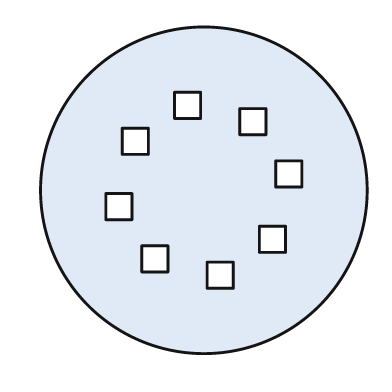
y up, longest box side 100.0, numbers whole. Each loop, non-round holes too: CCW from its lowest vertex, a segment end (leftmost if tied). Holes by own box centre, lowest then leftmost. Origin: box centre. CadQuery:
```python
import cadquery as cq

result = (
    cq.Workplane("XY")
    .moveTo(0.0, 0.0)
    .circle(50.0)
    .moveTo(1.0, -30.0)
    .lineTo(9.0, -30.0)
    .lineTo(9.0, -22.0)
    .lineTo(1.0, -22.0)
    .close()
    .moveTo(-19.0, -25.0)
    .lineTo(-11.0, -25.0)
    .lineTo(-11.0, -17.0)
    .lineTo(-19.0, -17.0)
    .close()
    .moveTo(17.0, -19.0)
    .lineTo(25.0, -19.0)
    .lineTo(25.0, -11.0)
    .lineTo(17.0, -11.0)
    .close()
    .moveTo(-30.0, -9.0)
    .lineTo(-22.0, -9.0)
    .lineTo(-22.0, -1.0)
    .lineTo(-30.0, -1.0)
    .close()
    .moveTo(22.0, 1.0)
    .lineTo(30.0, 1.0)
    .lineTo(30.0, 9.0)
    .lineTo(22.0, 9.0)
    .close()
    .moveTo(-25.0, 11.0)
    .lineTo(-17.0, 11.0)
    .lineTo(-17.0, 19.0)
    .lineTo(-25.0, 19.0)
    .close()
    .moveTo(11.0, 17.0)
    .lineTo(19.0, 17.0)
    .lineTo(19.0, 25.0)
    .lineTo(11.0, 25.0)
    .close()
    .moveTo(-9.0, 22.0)
    .lineTo(-1.0, 22.0)
    .lineTo(-1.0, 30.0)
    .lineTo(-9.0, 30.0)
    .close()
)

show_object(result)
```